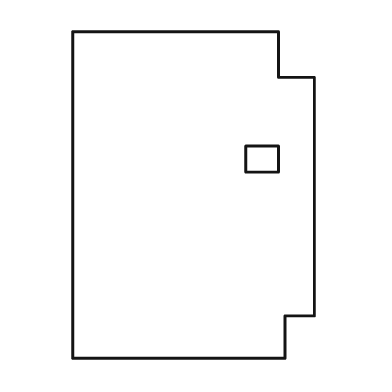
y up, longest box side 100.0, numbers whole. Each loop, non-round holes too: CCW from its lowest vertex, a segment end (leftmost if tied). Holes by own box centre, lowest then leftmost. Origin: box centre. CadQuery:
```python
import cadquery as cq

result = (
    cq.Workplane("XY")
    .moveTo(-37.0, -50.0)
    .lineTo(28.0, -50.0)
    .lineTo(28.0, -37.0)
    .lineTo(37.0, -37.0)
    .lineTo(37.0, 36.0)
    .lineTo(26.0, 36.0)
    .lineTo(26.0, 50.0)
    .lineTo(-37.0, 50.0)
    .close()
    .moveTo(16.0, 7.0)
    .lineTo(26.0, 7.0)
    .lineTo(26.0, 15.0)
    .lineTo(16.0, 15.0)
    .close()
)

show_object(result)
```